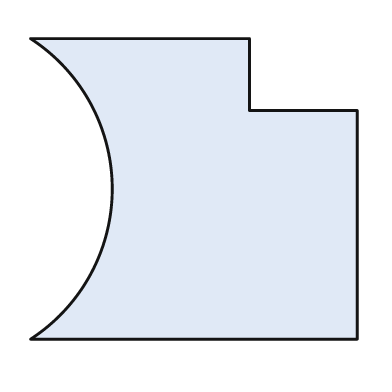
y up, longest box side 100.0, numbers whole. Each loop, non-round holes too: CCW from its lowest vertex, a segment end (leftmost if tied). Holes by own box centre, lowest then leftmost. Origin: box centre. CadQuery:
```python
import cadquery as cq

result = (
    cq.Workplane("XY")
    .moveTo(-50.0, -46.0)
    .lineTo(50.0, -46.0)
    .lineTo(50.0, 24.0)
    .lineTo(17.0, 24.0)
    .lineTo(17.0, 46.0)
    .lineTo(-50.0, 46.0)
    .threePointArc((-25.0, 0.0), (-50.0, -46.0))
    .close()
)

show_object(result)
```